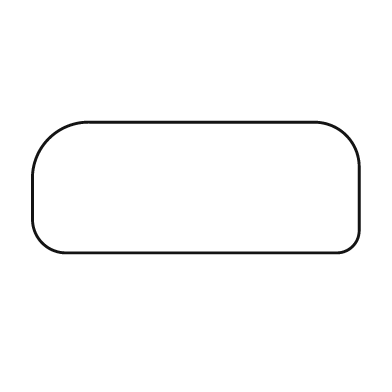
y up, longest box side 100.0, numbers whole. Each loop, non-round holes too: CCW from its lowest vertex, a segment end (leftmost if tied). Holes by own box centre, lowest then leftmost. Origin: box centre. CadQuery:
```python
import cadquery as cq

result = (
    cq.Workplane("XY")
    .moveTo(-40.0, -20.0)
    .lineTo(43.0, -20.0)
    .threePointArc((48.0, -18.0), (50.0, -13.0))
    .lineTo(50.0, 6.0)
    .threePointArc((46.0, 16.0), (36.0, 20.0))
    .lineTo(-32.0, 20.0)
    .threePointArc((-45.0, 15.0), (-50.0, 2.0))
    .lineTo(-50.0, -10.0)
    .threePointArc((-47.0, -17.0), (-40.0, -20.0))
    .close()
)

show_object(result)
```